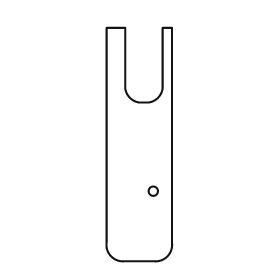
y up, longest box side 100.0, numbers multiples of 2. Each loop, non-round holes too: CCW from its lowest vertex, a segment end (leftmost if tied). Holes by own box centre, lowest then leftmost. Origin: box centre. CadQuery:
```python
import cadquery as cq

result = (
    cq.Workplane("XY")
    .moveTo(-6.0, -50.0)
    .lineTo(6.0, -50.0)
    .threePointArc((12.0, -48.0), (14.0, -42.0))
    .lineTo(14.0, 50.0)
    .lineTo(10.0, 50.0)
    .lineTo(10.0, 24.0)
    .threePointArc((8.0, 20.0), (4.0, 18.0))
    .lineTo(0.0, 18.0)
    .threePointArc((-4.0, 20.0), (-6.0, 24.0))
    .lineTo(-6.0, 50.0)
    .lineTo(-14.0, 50.0)
    .lineTo(-14.0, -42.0)
    .threePointArc((-12.0, -48.0), (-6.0, -50.0))
    .close()
    .moveTo(6.0, -20.0)
    .circle(2.0)
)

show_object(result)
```